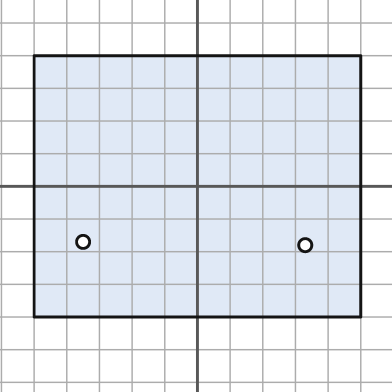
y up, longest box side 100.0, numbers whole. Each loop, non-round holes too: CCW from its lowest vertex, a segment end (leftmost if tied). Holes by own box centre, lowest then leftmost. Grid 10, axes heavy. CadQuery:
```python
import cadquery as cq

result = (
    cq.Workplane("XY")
    .moveTo(-50.0, -40.0)
    .lineTo(50.0, -40.0)
    .lineTo(50.0, 40.0)
    .lineTo(-50.0, 40.0)
    .close()
    .moveTo(33.0, -18.0)
    .circle(2.0)
    .moveTo(-35.0, -17.0)
    .circle(2.0)
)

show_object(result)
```